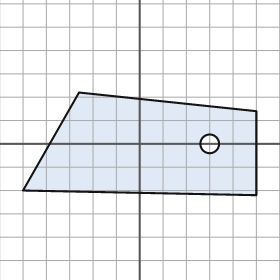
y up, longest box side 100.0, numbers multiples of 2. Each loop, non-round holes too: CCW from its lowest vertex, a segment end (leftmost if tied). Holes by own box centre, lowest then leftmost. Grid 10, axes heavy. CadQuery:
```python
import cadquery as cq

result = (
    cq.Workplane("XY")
    .moveTo(50.0, -22.0)
    .lineTo(50.0, 14.0)
    .lineTo(-26.0, 22.0)
    .lineTo(-50.0, -20.0)
    .close()
    .moveTo(30.0, 0.0)
    .circle(4.0)
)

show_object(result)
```